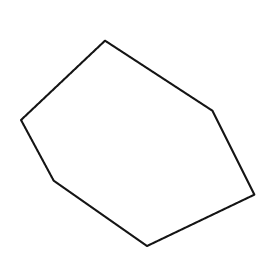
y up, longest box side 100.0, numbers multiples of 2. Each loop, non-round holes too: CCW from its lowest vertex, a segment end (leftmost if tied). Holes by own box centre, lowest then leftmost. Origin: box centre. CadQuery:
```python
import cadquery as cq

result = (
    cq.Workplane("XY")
    .moveTo(4.0, -44.0)
    .lineTo(50.0, -22.0)
    .lineTo(32.0, 14.0)
    .lineTo(-14.0, 44.0)
    .lineTo(-50.0, 10.0)
    .lineTo(-36.0, -16.0)
    .close()
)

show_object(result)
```